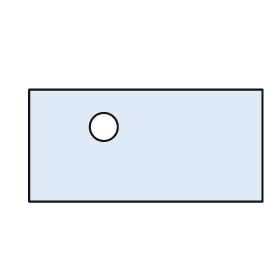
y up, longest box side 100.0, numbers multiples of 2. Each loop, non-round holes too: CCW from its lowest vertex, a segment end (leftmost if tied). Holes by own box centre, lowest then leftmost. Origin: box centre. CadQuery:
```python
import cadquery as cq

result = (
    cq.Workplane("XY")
    .moveTo(-50.0, -24.0)
    .lineTo(50.0, -24.0)
    .lineTo(50.0, 24.0)
    .lineTo(-50.0, 24.0)
    .close()
    .moveTo(-18.0, 8.0)
    .circle(6.0)
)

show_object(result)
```